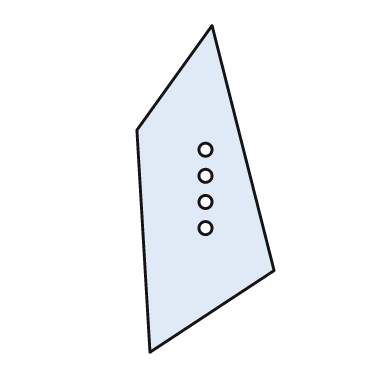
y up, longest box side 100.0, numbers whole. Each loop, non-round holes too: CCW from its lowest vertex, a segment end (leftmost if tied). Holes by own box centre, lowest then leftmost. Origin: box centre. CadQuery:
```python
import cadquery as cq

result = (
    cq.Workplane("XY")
    .moveTo(-17.0, -50.0)
    .lineTo(21.0, -25.0)
    .lineTo(2.0, 50.0)
    .lineTo(-21.0, 18.0)
    .close()
    .moveTo(0.0, -12.0)
    .circle(2.0)
    .moveTo(0.0, -4.0)
    .circle(2.0)
    .moveTo(0.0, 4.0)
    .circle(2.0)
    .moveTo(0.0, 12.0)
    .circle(2.0)
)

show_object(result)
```